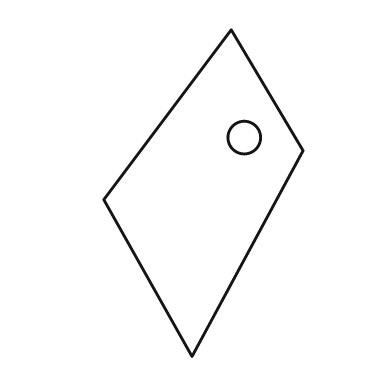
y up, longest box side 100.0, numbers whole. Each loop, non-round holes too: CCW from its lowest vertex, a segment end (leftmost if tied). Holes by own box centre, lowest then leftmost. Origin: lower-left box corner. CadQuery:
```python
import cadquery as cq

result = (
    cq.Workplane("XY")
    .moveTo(27.0, 0.0)
    .lineTo(61.0, 63.0)
    .lineTo(39.0, 100.0)
    .lineTo(0.0, 48.0)
    .close()
    .moveTo(43.0, 67.0)
    .circle(5.0)
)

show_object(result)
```